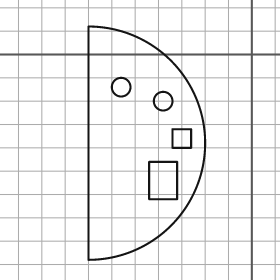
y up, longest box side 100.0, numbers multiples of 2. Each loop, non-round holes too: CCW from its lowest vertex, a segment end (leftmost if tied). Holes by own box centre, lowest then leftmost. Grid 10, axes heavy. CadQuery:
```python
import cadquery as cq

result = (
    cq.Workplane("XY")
    .moveTo(-70.0, -88.0)
    .threePointArc((-20.0, -38.0), (-70.0, 12.0))
    .close()
    .moveTo(-44.0, -62.0)
    .lineTo(-32.0, -62.0)
    .lineTo(-32.0, -46.0)
    .lineTo(-44.0, -46.0)
    .close()
    .moveTo(-34.0, -40.0)
    .lineTo(-26.0, -40.0)
    .lineTo(-26.0, -32.0)
    .lineTo(-34.0, -32.0)
    .close()
    .moveTo(-38.0, -20.0)
    .circle(4.0)
    .moveTo(-56.0, -14.0)
    .circle(4.0)
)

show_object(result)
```